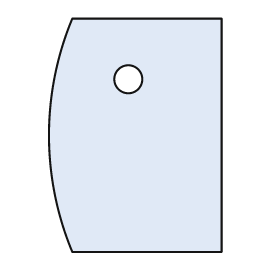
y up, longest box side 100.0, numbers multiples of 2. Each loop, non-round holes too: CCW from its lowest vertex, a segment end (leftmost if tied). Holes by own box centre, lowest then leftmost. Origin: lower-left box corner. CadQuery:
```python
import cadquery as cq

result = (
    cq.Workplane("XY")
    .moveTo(10.0, 0.0)
    .lineTo(74.0, 0.0)
    .lineTo(74.0, 100.0)
    .lineTo(10.0, 100.0)
    .threePointArc((0.0, 50.0), (10.0, 0.0))
    .close()
    .moveTo(34.0, 74.0)
    .circle(6.0)
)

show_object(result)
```